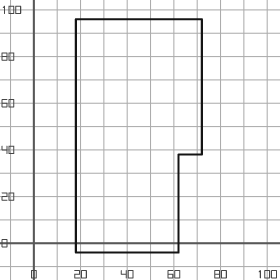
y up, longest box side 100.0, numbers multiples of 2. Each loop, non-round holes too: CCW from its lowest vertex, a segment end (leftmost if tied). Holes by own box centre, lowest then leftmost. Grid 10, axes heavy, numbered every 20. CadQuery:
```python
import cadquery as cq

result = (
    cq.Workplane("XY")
    .moveTo(18.0, -4.0)
    .lineTo(62.0, -4.0)
    .lineTo(62.0, 38.0)
    .lineTo(72.0, 38.0)
    .lineTo(72.0, 96.0)
    .lineTo(18.0, 96.0)
    .close()
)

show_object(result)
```